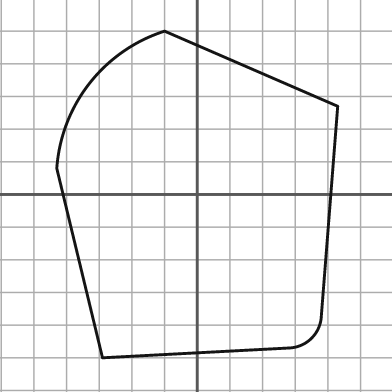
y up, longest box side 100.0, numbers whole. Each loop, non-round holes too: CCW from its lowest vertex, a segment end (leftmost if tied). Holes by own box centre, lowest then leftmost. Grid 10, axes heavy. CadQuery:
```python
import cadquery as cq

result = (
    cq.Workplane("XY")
    .moveTo(-29.0, -50.0)
    .lineTo(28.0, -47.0)
    .threePointArc((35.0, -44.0), (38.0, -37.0))
    .lineTo(43.0, 27.0)
    .lineTo(-10.0, 50.0)
    .threePointArc((-33.0, 34.0), (-43.0, 8.0))
    .close()
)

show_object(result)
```